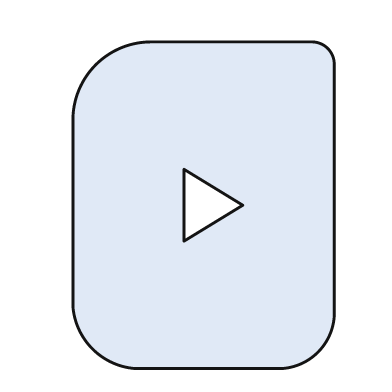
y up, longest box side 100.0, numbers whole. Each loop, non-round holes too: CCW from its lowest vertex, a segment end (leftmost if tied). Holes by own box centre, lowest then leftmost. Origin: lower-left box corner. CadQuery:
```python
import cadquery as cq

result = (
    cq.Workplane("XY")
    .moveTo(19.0, 0.0)
    .lineTo(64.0, 0.0)
    .threePointArc((75.0, 5.0), (80.0, 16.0))
    .lineTo(80.0, 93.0)
    .threePointArc((78.0, 98.0), (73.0, 100.0))
    .lineTo(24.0, 100.0)
    .threePointArc((7.0, 93.0), (0.0, 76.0))
    .lineTo(0.0, 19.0)
    .threePointArc((6.0, 6.0), (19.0, 0.0))
    .close()
    .moveTo(34.0, 39.0)
    .lineTo(52.0, 50.0)
    .lineTo(34.0, 61.0)
    .close()
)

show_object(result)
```